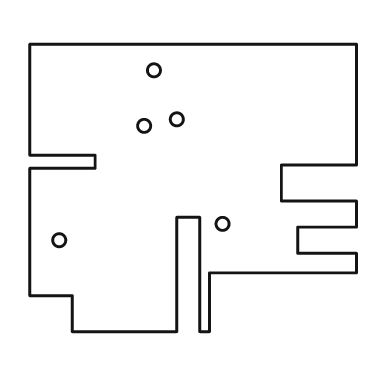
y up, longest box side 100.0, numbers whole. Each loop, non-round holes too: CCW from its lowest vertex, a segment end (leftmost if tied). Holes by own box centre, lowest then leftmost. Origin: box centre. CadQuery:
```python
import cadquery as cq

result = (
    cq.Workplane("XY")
    .moveTo(-37.0, -44.0)
    .lineTo(-5.0, -44.0)
    .lineTo(-5.0, -9.0)
    .lineTo(2.0, -9.0)
    .lineTo(2.0, -44.0)
    .lineTo(5.0, -44.0)
    .lineTo(5.0, -26.0)
    .lineTo(50.0, -26.0)
    .lineTo(50.0, -20.0)
    .lineTo(32.0, -20.0)
    .lineTo(32.0, -12.0)
    .lineTo(50.0, -12.0)
    .lineTo(50.0, -4.0)
    .lineTo(27.0, -4.0)
    .lineTo(27.0, 7.0)
    .lineTo(50.0, 7.0)
    .lineTo(50.0, 44.0)
    .lineTo(-50.0, 44.0)
    .lineTo(-50.0, 10.0)
    .lineTo(-30.0, 10.0)
    .lineTo(-30.0, 6.0)
    .lineTo(-50.0, 6.0)
    .lineTo(-50.0, -33.0)
    .lineTo(-37.0, -33.0)
    .close()
    .moveTo(-41.0, -16.0)
    .circle(2.0)
    .moveTo(9.0, -11.0)
    .circle(2.0)
    .moveTo(-15.0, 19.0)
    .circle(2.0)
    .moveTo(-5.0, 21.0)
    .circle(2.0)
    .moveTo(-12.0, 36.0)
    .circle(2.0)
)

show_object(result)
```